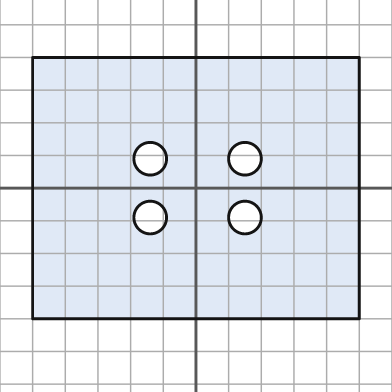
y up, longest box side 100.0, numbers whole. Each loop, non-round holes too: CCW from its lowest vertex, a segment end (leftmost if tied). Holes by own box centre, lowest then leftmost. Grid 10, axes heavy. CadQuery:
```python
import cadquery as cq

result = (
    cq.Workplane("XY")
    .moveTo(-50.0, -40.0)
    .lineTo(50.0, -40.0)
    .lineTo(50.0, 40.0)
    .lineTo(-50.0, 40.0)
    .close()
    .moveTo(-14.0, -9.0)
    .circle(5.0)
    .moveTo(15.0, -9.0)
    .circle(5.0)
    .moveTo(-14.0, 9.0)
    .circle(5.0)
    .moveTo(15.0, 9.0)
    .circle(5.0)
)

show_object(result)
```